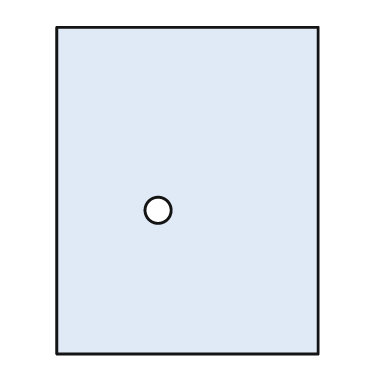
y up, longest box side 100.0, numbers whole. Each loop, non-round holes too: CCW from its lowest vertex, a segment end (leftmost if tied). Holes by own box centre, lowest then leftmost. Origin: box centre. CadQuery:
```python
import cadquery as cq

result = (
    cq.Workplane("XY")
    .moveTo(-40.0, -50.0)
    .lineTo(40.0, -50.0)
    .lineTo(40.0, 50.0)
    .lineTo(-40.0, 50.0)
    .close()
    .moveTo(-9.0, -6.0)
    .circle(4.0)
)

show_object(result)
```